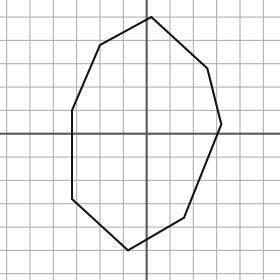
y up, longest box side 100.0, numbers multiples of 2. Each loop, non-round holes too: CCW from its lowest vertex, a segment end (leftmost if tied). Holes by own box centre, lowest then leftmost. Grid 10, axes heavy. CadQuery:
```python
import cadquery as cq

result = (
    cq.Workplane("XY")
    .moveTo(-8.0, -50.0)
    .lineTo(16.0, -36.0)
    .lineTo(32.0, 4.0)
    .lineTo(26.0, 28.0)
    .lineTo(2.0, 50.0)
    .lineTo(-20.0, 38.0)
    .lineTo(-32.0, 10.0)
    .lineTo(-32.0, -28.0)
    .close()
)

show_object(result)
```